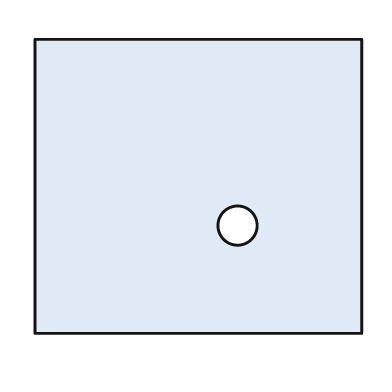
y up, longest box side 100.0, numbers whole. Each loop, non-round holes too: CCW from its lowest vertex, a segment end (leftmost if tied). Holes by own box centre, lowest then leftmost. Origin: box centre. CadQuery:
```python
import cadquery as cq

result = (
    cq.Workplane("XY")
    .moveTo(-50.0, -45.0)
    .lineTo(50.0, -45.0)
    .lineTo(50.0, 45.0)
    .lineTo(-50.0, 45.0)
    .close()
    .moveTo(12.0, -12.0)
    .circle(6.0)
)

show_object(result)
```